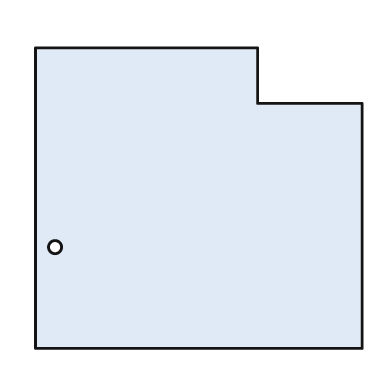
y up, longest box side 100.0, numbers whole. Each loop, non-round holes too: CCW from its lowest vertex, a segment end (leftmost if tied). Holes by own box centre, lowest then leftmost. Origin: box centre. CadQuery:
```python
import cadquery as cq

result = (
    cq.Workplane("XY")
    .moveTo(-50.0, -46.0)
    .lineTo(50.0, -46.0)
    .lineTo(50.0, 29.0)
    .lineTo(18.0, 29.0)
    .lineTo(18.0, 46.0)
    .lineTo(-50.0, 46.0)
    .close()
    .moveTo(-44.0, -15.0)
    .circle(2.0)
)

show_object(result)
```